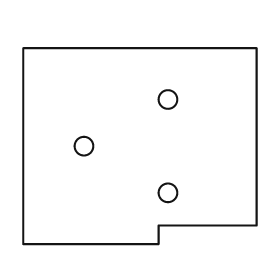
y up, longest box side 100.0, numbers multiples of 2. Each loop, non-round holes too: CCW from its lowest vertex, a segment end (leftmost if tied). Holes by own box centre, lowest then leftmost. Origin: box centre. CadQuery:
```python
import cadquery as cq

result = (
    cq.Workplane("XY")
    .moveTo(-50.0, -42.0)
    .lineTo(8.0, -42.0)
    .lineTo(8.0, -34.0)
    .lineTo(50.0, -34.0)
    .lineTo(50.0, 42.0)
    .lineTo(-50.0, 42.0)
    .close()
    .moveTo(12.0, -20.0)
    .circle(4.0)
    .moveTo(-24.0, 0.0)
    .circle(4.0)
    .moveTo(12.0, 20.0)
    .circle(4.0)
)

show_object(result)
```